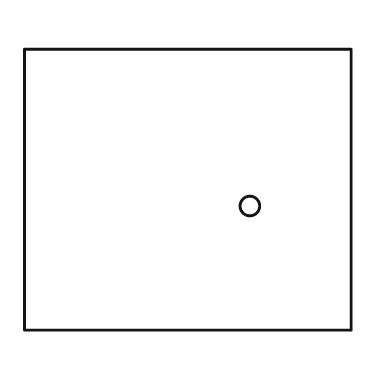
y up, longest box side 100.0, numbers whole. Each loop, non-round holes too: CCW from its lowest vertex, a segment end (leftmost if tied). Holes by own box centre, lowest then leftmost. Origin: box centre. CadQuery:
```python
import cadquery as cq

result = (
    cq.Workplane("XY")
    .moveTo(-50.0, -43.0)
    .lineTo(50.0, -43.0)
    .lineTo(50.0, 43.0)
    .lineTo(-50.0, 43.0)
    .close()
    .moveTo(19.0, -5.0)
    .circle(3.0)
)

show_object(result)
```